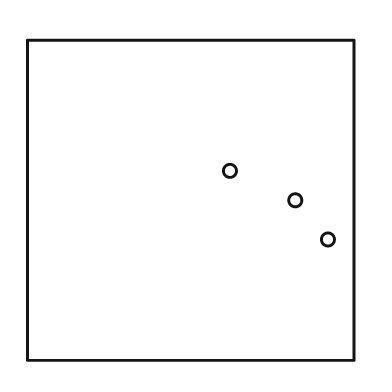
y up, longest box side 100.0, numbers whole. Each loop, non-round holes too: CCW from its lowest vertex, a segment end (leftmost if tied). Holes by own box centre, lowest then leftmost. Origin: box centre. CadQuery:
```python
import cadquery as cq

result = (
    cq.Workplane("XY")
    .moveTo(-50.0, -49.0)
    .lineTo(50.0, -49.0)
    .lineTo(50.0, 49.0)
    .lineTo(-50.0, 49.0)
    .close()
    .moveTo(42.0, -12.0)
    .circle(2.0)
    .moveTo(32.0, 0.0)
    .circle(2.0)
    .moveTo(12.0, 9.0)
    .circle(2.0)
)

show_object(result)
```